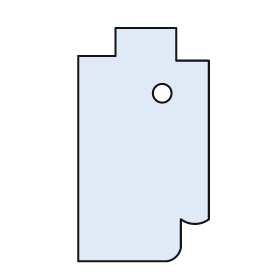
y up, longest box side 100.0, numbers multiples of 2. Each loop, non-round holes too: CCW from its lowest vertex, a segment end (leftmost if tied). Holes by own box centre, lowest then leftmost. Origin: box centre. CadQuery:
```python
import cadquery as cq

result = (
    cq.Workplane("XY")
    .moveTo(-28.0, -50.0)
    .lineTo(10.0, -50.0)
    .threePointArc((14.0, -48.0), (16.0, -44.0))
    .lineTo(16.0, -32.0)
    .threePointArc((22.0, -34.0), (28.0, -32.0))
    .lineTo(28.0, 36.0)
    .lineTo(14.0, 36.0)
    .lineTo(14.0, 50.0)
    .lineTo(-12.0, 50.0)
    .lineTo(-12.0, 38.0)
    .lineTo(-28.0, 38.0)
    .close()
    .moveTo(8.0, 22.0)
    .circle(4.0)
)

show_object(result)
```